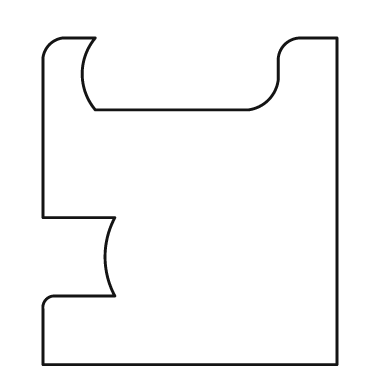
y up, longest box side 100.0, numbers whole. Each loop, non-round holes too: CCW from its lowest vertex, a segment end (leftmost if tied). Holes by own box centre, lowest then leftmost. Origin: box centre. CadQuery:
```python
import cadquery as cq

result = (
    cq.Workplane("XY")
    .moveTo(-45.0, -50.0)
    .lineTo(45.0, -50.0)
    .lineTo(45.0, 50.0)
    .lineTo(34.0, 50.0)
    .threePointArc((29.0, 48.0), (27.0, 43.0))
    .lineTo(27.0, 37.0)
    .threePointArc((24.0, 31.0), (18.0, 28.0))
    .lineTo(-29.0, 28.0)
    .threePointArc((-33.0, 39.0), (-29.0, 50.0))
    .lineTo(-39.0, 50.0)
    .threePointArc((-43.0, 48.0), (-45.0, 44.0))
    .lineTo(-45.0, -5.0)
    .lineTo(-23.0, -5.0)
    .threePointArc((-26.0, -17.0), (-23.0, -29.0))
    .lineTo(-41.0, -29.0)
    .threePointArc((-44.0, -30.0), (-45.0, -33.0))
    .close()
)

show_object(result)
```